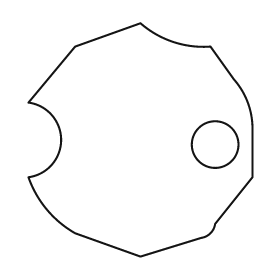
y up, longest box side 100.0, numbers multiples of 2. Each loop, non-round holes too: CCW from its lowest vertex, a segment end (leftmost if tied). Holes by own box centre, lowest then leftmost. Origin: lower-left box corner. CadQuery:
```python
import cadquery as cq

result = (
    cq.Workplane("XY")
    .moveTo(48.0, 0.0)
    .lineTo(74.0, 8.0)
    .threePointArc((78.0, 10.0), (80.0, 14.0))
    .lineTo(96.0, 34.0)
    .lineTo(96.0, 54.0)
    .threePointArc((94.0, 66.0), (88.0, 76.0))
    .lineTo(78.0, 90.0)
    .threePointArc((62.0, 92.0), (48.0, 100.0))
    .lineTo(20.0, 90.0)
    .lineTo(0.0, 66.0)
    .threePointArc((14.0, 50.0), (0.0, 34.0))
    .threePointArc((8.0, 20.0), (20.0, 10.0))
    .close()
    .moveTo(80.0, 48.0)
    .circle(10.0)
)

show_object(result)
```